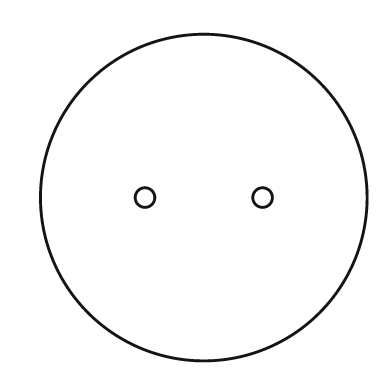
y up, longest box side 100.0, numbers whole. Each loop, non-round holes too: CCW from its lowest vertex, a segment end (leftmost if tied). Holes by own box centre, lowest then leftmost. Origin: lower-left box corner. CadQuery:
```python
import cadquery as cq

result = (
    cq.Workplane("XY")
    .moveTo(50.0, 50.0)
    .circle(50.0)
    .moveTo(32.0, 50.0)
    .circle(3.0)
    .moveTo(68.0, 50.0)
    .circle(3.0)
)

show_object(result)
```